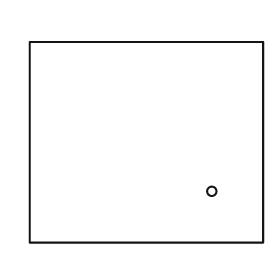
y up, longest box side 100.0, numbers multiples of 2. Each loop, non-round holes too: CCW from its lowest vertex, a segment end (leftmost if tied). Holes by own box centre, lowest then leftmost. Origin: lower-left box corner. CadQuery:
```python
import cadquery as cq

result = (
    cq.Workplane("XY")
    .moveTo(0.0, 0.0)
    .lineTo(100.0, 0.0)
    .lineTo(100.0, 86.0)
    .lineTo(0.0, 86.0)
    .close()
    .moveTo(78.0, 22.0)
    .circle(2.0)
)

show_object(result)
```